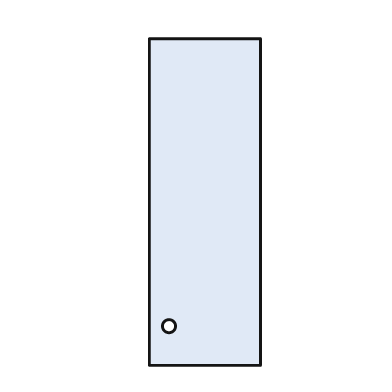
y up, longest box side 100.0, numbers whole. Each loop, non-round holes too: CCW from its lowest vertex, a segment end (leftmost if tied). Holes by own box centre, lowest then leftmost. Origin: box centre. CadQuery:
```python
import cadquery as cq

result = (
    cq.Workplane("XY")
    .moveTo(-17.0, -50.0)
    .lineTo(17.0, -50.0)
    .lineTo(17.0, 50.0)
    .lineTo(-17.0, 50.0)
    .close()
    .moveTo(-11.0, -38.0)
    .circle(2.0)
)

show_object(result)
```